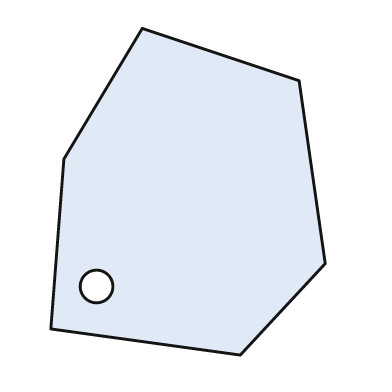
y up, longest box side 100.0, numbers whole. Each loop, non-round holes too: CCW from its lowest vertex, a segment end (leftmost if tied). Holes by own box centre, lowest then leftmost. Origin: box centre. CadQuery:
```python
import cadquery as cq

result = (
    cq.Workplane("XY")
    .moveTo(16.0, -50.0)
    .lineTo(42.0, -22.0)
    .lineTo(34.0, 34.0)
    .lineTo(-14.0, 50.0)
    .lineTo(-38.0, 10.0)
    .lineTo(-42.0, -42.0)
    .close()
    .moveTo(-28.0, -29.0)
    .circle(5.0)
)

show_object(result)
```